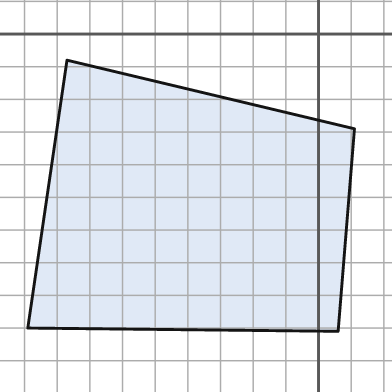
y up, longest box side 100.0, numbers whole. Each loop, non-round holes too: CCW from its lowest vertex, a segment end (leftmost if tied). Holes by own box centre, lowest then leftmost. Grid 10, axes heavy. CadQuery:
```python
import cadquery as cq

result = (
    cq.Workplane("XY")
    .moveTo(6.0, -91.0)
    .lineTo(11.0, -29.0)
    .lineTo(-77.0, -8.0)
    .lineTo(-89.0, -90.0)
    .close()
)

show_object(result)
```